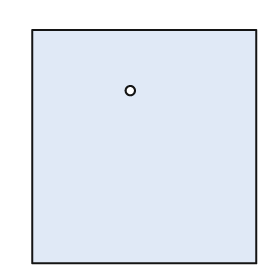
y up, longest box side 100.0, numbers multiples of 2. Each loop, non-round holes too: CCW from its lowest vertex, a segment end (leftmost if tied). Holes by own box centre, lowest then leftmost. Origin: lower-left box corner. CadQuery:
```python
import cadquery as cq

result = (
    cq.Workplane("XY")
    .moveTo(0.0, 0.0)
    .lineTo(96.0, 0.0)
    .lineTo(96.0, 100.0)
    .lineTo(0.0, 100.0)
    .close()
    .moveTo(42.0, 74.0)
    .circle(2.0)
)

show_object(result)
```